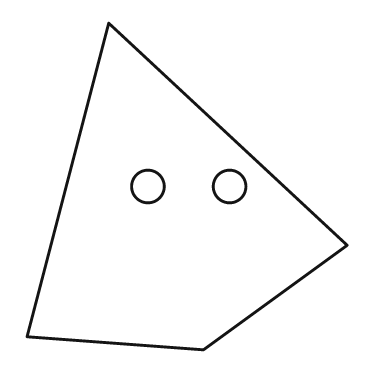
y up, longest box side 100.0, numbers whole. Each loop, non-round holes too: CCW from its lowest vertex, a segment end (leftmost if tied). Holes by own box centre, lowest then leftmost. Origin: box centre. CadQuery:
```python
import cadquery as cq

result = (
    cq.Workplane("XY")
    .moveTo(5.0, -50.0)
    .lineTo(49.0, -18.0)
    .lineTo(-24.0, 50.0)
    .lineTo(-49.0, -46.0)
    .close()
    .moveTo(-12.0, 0.0)
    .circle(5.0)
    .moveTo(13.0, 0.0)
    .circle(5.0)
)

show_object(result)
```